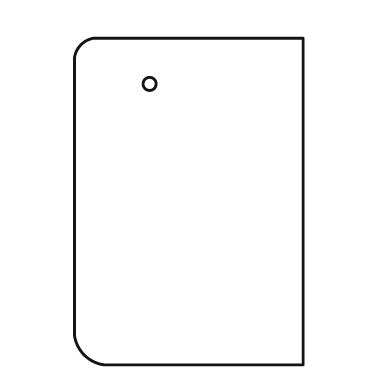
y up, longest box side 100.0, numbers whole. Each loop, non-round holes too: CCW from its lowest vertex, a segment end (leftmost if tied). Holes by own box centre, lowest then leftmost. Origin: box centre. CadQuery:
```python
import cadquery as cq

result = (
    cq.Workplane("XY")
    .moveTo(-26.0, -50.0)
    .lineTo(35.0, -50.0)
    .lineTo(35.0, 50.0)
    .lineTo(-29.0, 50.0)
    .threePointArc((-33.0, 48.0), (-35.0, 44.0))
    .lineTo(-35.0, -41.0)
    .threePointArc((-32.0, -47.0), (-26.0, -50.0))
    .close()
    .moveTo(-12.0, 36.0)
    .circle(2.0)
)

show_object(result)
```